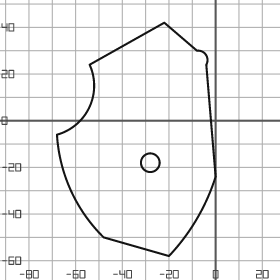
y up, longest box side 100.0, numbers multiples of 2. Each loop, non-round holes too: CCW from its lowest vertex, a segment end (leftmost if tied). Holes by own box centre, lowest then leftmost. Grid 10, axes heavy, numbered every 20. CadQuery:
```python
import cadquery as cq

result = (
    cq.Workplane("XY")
    .moveTo(-20.0, -58.0)
    .threePointArc((-8.0, -42.0), (0.0, -24.0))
    .lineTo(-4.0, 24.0)
    .threePointArc((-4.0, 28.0), (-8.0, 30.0))
    .lineTo(-22.0, 42.0)
    .lineTo(-54.0, 24.0)
    .threePointArc((-54.0, 6.0), (-68.0, -6.0))
    .threePointArc((-62.0, -30.0), (-48.0, -50.0))
    .close()
    .moveTo(-28.0, -18.0)
    .circle(4.0)
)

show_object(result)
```